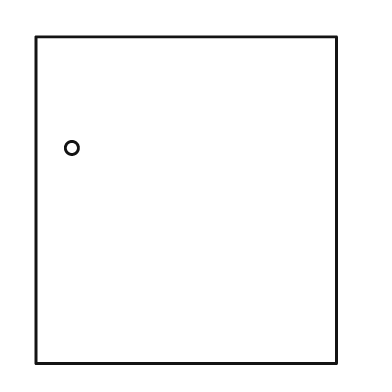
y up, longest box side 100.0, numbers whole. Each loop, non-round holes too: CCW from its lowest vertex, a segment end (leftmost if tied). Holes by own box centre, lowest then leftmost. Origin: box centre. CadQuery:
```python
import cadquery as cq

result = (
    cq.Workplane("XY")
    .moveTo(-46.0, -50.0)
    .lineTo(46.0, -50.0)
    .lineTo(46.0, 50.0)
    .lineTo(-46.0, 50.0)
    .close()
    .moveTo(-35.0, 16.0)
    .circle(2.0)
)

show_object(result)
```